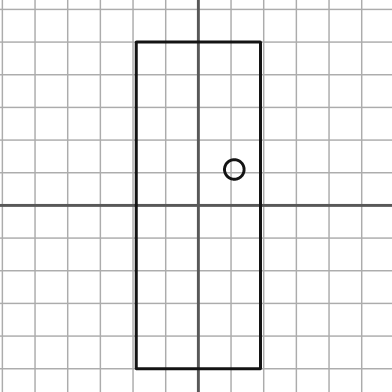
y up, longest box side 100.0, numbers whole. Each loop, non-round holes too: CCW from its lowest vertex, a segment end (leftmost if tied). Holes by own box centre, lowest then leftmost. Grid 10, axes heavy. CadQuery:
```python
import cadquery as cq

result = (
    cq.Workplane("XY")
    .moveTo(-19.0, -50.0)
    .lineTo(19.0, -50.0)
    .lineTo(19.0, 50.0)
    .lineTo(-19.0, 50.0)
    .close()
    .moveTo(11.0, 11.0)
    .circle(3.0)
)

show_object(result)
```